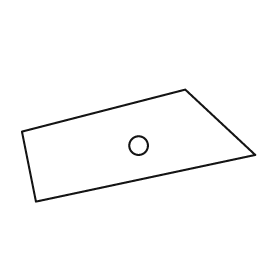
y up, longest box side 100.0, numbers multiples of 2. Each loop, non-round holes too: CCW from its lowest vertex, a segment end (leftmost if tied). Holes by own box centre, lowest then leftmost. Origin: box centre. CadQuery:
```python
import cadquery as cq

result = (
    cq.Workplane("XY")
    .moveTo(-44.0, -24.0)
    .lineTo(50.0, -4.0)
    .lineTo(20.0, 24.0)
    .lineTo(-50.0, 6.0)
    .close()
    .moveTo(0.0, 0.0)
    .circle(4.0)
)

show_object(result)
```